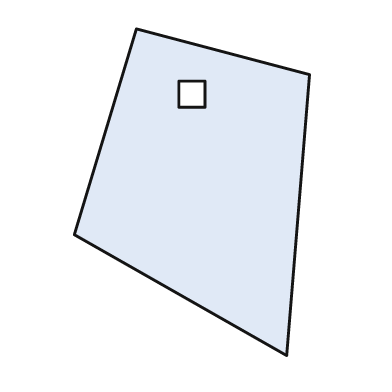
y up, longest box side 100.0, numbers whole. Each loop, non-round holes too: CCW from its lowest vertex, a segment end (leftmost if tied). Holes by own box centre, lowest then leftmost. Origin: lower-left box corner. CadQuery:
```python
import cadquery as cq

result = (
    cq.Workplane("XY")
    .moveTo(65.0, 0.0)
    .lineTo(72.0, 86.0)
    .lineTo(19.0, 100.0)
    .lineTo(0.0, 37.0)
    .close()
    .moveTo(32.0, 76.0)
    .lineTo(40.0, 76.0)
    .lineTo(40.0, 84.0)
    .lineTo(32.0, 84.0)
    .close()
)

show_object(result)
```